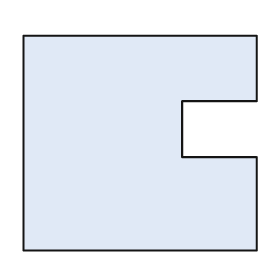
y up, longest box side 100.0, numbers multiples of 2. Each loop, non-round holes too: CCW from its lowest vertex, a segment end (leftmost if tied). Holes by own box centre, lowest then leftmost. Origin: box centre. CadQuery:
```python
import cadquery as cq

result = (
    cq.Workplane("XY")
    .moveTo(-50.0, -46.0)
    .lineTo(50.0, -46.0)
    .lineTo(50.0, -6.0)
    .lineTo(18.0, -6.0)
    .lineTo(18.0, 18.0)
    .lineTo(50.0, 18.0)
    .lineTo(50.0, 46.0)
    .lineTo(-50.0, 46.0)
    .close()
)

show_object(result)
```